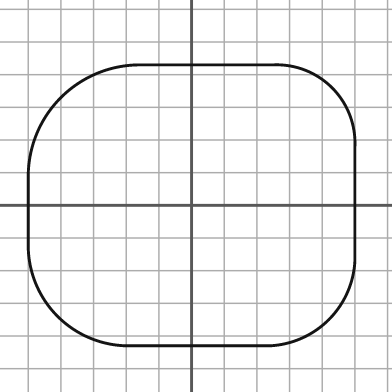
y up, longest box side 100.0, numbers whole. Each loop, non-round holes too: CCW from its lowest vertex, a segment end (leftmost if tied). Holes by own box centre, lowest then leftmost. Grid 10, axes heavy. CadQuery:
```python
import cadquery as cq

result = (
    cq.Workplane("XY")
    .moveTo(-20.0, -43.0)
    .lineTo(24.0, -43.0)
    .threePointArc((42.0, -35.0), (50.0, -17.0))
    .lineTo(50.0, 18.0)
    .threePointArc((43.0, 36.0), (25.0, 43.0))
    .lineTo(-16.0, 43.0)
    .threePointArc((-40.0, 33.0), (-50.0, 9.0))
    .lineTo(-50.0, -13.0)
    .threePointArc((-41.0, -34.0), (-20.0, -43.0))
    .close()
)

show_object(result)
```